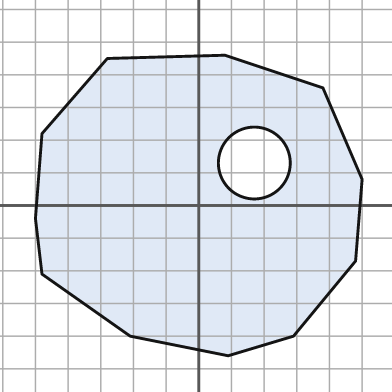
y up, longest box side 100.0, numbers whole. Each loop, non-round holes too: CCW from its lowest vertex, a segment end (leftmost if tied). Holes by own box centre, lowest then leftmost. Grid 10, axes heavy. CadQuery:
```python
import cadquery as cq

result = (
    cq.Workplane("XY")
    .moveTo(9.0, -46.0)
    .lineTo(29.0, -40.0)
    .lineTo(48.0, -17.0)
    .lineTo(50.0, 8.0)
    .lineTo(38.0, 36.0)
    .lineTo(8.0, 46.0)
    .lineTo(-28.0, 45.0)
    .lineTo(-48.0, 22.0)
    .lineTo(-50.0, -4.0)
    .lineTo(-48.0, -21.0)
    .lineTo(-21.0, -40.0)
    .close()
    .moveTo(17.0, 13.0)
    .circle(11.0)
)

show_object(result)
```